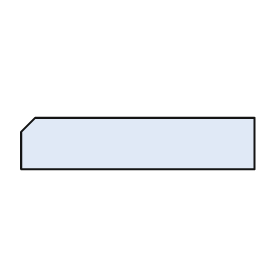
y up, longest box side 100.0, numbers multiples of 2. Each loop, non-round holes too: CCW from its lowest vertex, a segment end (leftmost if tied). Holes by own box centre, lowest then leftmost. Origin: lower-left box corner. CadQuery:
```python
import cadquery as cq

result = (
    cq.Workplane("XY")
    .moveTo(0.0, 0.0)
    .lineTo(100.0, 0.0)
    .lineTo(100.0, 22.0)
    .lineTo(6.0, 22.0)
    .lineTo(0.0, 16.0)
    .close()
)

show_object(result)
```